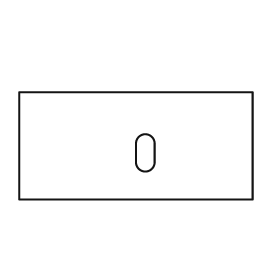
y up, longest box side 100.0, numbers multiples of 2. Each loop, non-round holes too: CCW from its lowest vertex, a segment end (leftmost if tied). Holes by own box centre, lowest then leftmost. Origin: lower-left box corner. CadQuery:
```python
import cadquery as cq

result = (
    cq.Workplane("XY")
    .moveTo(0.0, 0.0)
    .lineTo(100.0, 0.0)
    .lineTo(100.0, 46.0)
    .lineTo(0.0, 46.0)
    .close()
    .moveTo(50.0, 16.0)
    .threePointArc((54.0, 12.0), (58.0, 16.0))
    .lineTo(58.0, 24.0)
    .threePointArc((54.0, 28.0), (50.0, 24.0))
    .close()
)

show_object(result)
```